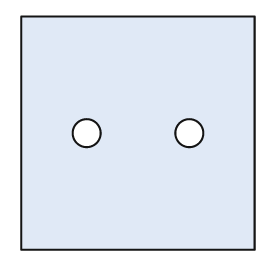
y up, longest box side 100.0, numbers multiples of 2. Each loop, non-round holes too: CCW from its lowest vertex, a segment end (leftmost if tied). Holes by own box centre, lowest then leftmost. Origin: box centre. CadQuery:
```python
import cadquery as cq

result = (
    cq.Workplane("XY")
    .moveTo(-50.0, -50.0)
    .lineTo(50.0, -50.0)
    .lineTo(50.0, 50.0)
    .lineTo(-50.0, 50.0)
    .close()
    .moveTo(-22.0, 0.0)
    .circle(6.0)
    .moveTo(22.0, 0.0)
    .circle(6.0)
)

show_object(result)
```